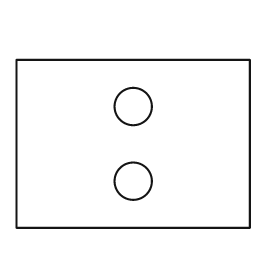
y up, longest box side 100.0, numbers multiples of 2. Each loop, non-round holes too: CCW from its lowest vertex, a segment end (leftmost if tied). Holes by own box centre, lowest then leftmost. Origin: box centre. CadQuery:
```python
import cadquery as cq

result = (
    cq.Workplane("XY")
    .moveTo(-50.0, -36.0)
    .lineTo(50.0, -36.0)
    .lineTo(50.0, 36.0)
    .lineTo(-50.0, 36.0)
    .close()
    .moveTo(0.0, -16.0)
    .circle(8.0)
    .moveTo(0.0, 16.0)
    .circle(8.0)
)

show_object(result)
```